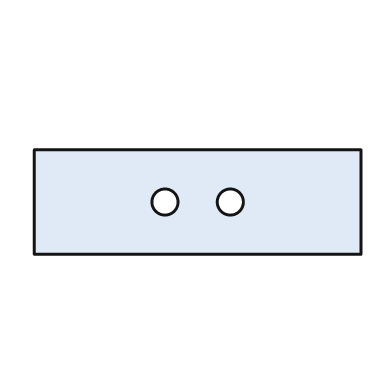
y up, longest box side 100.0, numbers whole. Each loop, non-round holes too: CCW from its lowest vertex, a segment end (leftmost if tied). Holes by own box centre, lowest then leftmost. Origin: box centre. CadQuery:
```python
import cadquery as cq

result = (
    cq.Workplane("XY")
    .moveTo(-50.0, -16.0)
    .lineTo(50.0, -16.0)
    .lineTo(50.0, 16.0)
    .lineTo(-50.0, 16.0)
    .close()
    .moveTo(-10.0, 0.0)
    .circle(4.0)
    .moveTo(10.0, 0.0)
    .circle(4.0)
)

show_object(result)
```